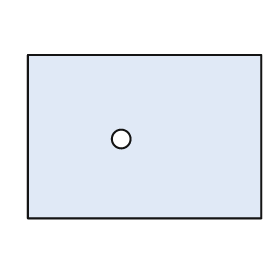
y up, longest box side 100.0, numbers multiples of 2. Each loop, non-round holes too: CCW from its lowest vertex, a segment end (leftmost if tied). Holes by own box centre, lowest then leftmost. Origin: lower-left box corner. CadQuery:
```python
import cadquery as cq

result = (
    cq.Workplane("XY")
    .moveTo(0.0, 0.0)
    .lineTo(100.0, 0.0)
    .lineTo(100.0, 70.0)
    .lineTo(0.0, 70.0)
    .close()
    .moveTo(40.0, 34.0)
    .circle(4.0)
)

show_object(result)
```